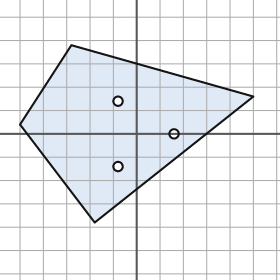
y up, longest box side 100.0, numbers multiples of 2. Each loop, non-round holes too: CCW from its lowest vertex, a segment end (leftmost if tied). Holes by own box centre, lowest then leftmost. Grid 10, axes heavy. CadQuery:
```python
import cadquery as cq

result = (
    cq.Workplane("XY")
    .moveTo(-18.0, -38.0)
    .lineTo(50.0, 16.0)
    .lineTo(-28.0, 38.0)
    .lineTo(-50.0, 4.0)
    .close()
    .moveTo(-8.0, -14.0)
    .circle(2.0)
    .moveTo(16.0, 0.0)
    .circle(2.0)
    .moveTo(-8.0, 14.0)
    .circle(2.0)
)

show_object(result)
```